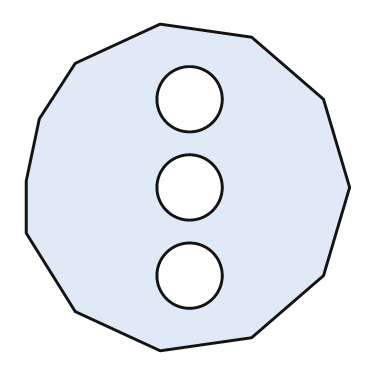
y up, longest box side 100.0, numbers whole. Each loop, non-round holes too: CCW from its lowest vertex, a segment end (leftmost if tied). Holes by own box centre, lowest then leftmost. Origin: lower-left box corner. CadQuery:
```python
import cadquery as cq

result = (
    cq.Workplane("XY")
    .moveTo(41.0, 0.0)
    .lineTo(69.0, 4.0)
    .lineTo(91.0, 23.0)
    .lineTo(99.0, 50.0)
    .lineTo(91.0, 77.0)
    .lineTo(69.0, 96.0)
    .lineTo(41.0, 100.0)
    .lineTo(15.0, 88.0)
    .lineTo(4.0, 71.0)
    .lineTo(0.0, 52.0)
    .lineTo(0.0, 36.0)
    .lineTo(15.0, 12.0)
    .close()
    .moveTo(50.0, 23.0)
    .circle(10.0)
    .moveTo(50.0, 50.0)
    .circle(10.0)
    .moveTo(50.0, 77.0)
    .circle(10.0)
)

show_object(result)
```